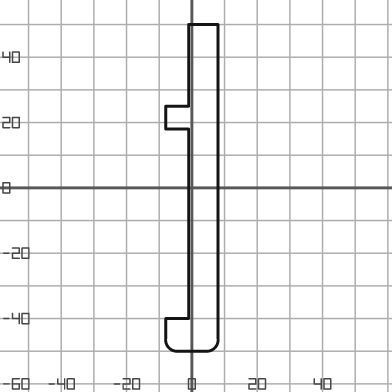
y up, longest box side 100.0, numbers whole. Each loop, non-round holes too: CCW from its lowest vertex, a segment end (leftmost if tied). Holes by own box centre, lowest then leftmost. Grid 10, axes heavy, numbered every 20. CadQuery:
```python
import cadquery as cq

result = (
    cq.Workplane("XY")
    .moveTo(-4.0, -50.0)
    .lineTo(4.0, -50.0)
    .threePointArc((7.0, -49.0), (8.0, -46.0))
    .lineTo(8.0, 50.0)
    .lineTo(-1.0, 50.0)
    .lineTo(-1.0, 25.0)
    .lineTo(-8.0, 25.0)
    .lineTo(-8.0, 18.0)
    .lineTo(-1.0, 18.0)
    .lineTo(-1.0, -40.0)
    .lineTo(-8.0, -40.0)
    .lineTo(-8.0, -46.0)
    .threePointArc((-7.0, -49.0), (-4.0, -50.0))
    .close()
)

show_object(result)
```